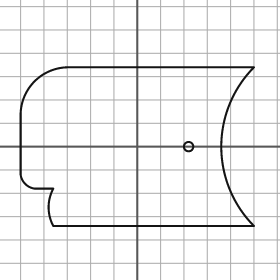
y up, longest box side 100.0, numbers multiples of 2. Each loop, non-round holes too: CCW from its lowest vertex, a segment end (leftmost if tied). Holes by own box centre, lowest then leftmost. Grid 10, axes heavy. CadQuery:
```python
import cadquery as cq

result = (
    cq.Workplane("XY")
    .moveTo(-36.0, -34.0)
    .lineTo(50.0, -34.0)
    .threePointArc((36.0, 0.0), (50.0, 34.0))
    .lineTo(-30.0, 34.0)
    .threePointArc((-44.0, 28.0), (-50.0, 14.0))
    .lineTo(-50.0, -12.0)
    .threePointArc((-48.0, -16.0), (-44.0, -18.0))
    .lineTo(-36.0, -18.0)
    .threePointArc((-38.0, -26.0), (-36.0, -34.0))
    .close()
    .moveTo(22.0, 0.0)
    .circle(2.0)
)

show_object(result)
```